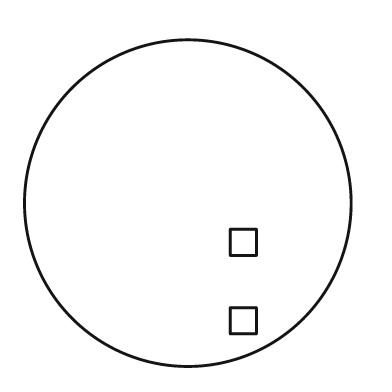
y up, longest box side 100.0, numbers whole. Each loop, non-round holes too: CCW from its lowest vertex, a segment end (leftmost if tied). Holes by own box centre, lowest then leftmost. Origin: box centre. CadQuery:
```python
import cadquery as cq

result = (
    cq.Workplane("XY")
    .moveTo(0.0, 0.0)
    .circle(50.0)
    .moveTo(13.0, -40.0)
    .lineTo(21.0, -40.0)
    .lineTo(21.0, -32.0)
    .lineTo(13.0, -32.0)
    .close()
    .moveTo(13.0, -16.0)
    .lineTo(21.0, -16.0)
    .lineTo(21.0, -8.0)
    .lineTo(13.0, -8.0)
    .close()
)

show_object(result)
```